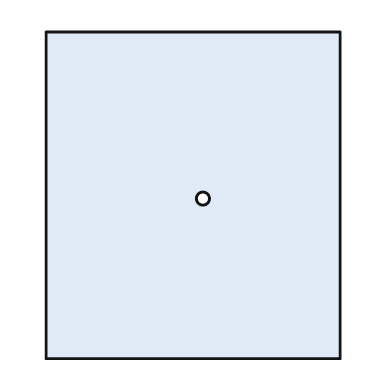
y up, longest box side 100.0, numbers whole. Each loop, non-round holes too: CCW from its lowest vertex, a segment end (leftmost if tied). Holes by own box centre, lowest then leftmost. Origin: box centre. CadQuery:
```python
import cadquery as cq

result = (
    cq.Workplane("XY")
    .moveTo(-45.0, -50.0)
    .lineTo(45.0, -50.0)
    .lineTo(45.0, 50.0)
    .lineTo(-45.0, 50.0)
    .close()
    .moveTo(3.0, -1.0)
    .circle(2.0)
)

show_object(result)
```